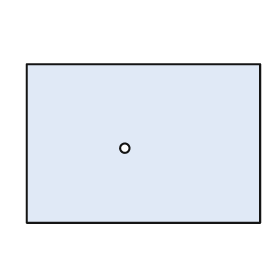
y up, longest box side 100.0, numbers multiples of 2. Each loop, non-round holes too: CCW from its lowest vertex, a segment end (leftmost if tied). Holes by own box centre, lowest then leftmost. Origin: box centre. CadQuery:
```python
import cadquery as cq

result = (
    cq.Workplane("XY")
    .moveTo(-50.0, -34.0)
    .lineTo(50.0, -34.0)
    .lineTo(50.0, 34.0)
    .lineTo(-50.0, 34.0)
    .close()
    .moveTo(-8.0, -2.0)
    .circle(2.0)
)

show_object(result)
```